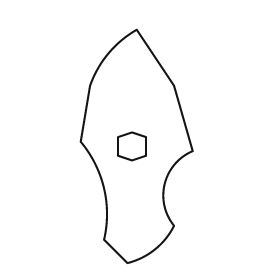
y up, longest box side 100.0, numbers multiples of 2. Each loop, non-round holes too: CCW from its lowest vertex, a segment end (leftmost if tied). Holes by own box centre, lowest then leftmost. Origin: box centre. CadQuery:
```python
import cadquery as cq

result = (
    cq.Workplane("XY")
    .moveTo(-4.0, -50.0)
    .threePointArc((8.0, -44.0), (16.0, -34.0))
    .threePointArc((12.0, -16.0), (24.0, -2.0))
    .lineTo(16.0, 26.0)
    .lineTo(0.0, 50.0)
    .threePointArc((-12.0, 40.0), (-20.0, 26.0))
    .lineTo(-24.0, 2.0)
    .threePointArc((-14.0, -18.0), (-14.0, -40.0))
    .close()
    .moveTo(-2.0, -6.0)
    .lineTo(4.0, -4.0)
    .lineTo(4.0, 4.0)
    .lineTo(-2.0, 6.0)
    .lineTo(-8.0, 4.0)
    .lineTo(-8.0, -4.0)
    .close()
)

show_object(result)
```